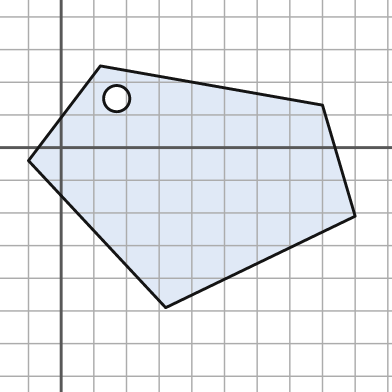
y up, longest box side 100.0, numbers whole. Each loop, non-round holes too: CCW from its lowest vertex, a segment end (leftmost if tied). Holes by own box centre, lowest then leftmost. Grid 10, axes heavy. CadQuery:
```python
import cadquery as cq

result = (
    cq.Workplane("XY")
    .moveTo(32.0, -49.0)
    .lineTo(90.0, -21.0)
    .lineTo(80.0, 13.0)
    .lineTo(12.0, 25.0)
    .lineTo(-10.0, -4.0)
    .close()
    .moveTo(17.0, 15.0)
    .circle(4.0)
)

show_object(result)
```